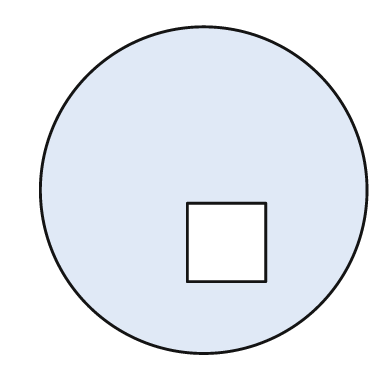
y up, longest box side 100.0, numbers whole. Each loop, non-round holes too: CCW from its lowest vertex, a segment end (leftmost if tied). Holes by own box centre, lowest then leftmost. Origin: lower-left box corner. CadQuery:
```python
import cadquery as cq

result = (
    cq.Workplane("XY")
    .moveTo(50.0, 50.0)
    .circle(50.0)
    .moveTo(45.0, 22.0)
    .lineTo(69.0, 22.0)
    .lineTo(69.0, 46.0)
    .lineTo(45.0, 46.0)
    .close()
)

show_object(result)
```